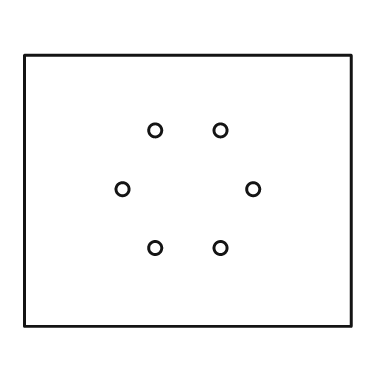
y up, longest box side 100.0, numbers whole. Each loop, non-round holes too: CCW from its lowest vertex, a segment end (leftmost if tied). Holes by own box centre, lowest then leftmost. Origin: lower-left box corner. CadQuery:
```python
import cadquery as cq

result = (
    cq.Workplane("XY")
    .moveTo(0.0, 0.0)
    .lineTo(100.0, 0.0)
    .lineTo(100.0, 83.0)
    .lineTo(0.0, 83.0)
    .close()
    .moveTo(40.0, 24.0)
    .circle(2.0)
    .moveTo(60.0, 24.0)
    .circle(2.0)
    .moveTo(30.0, 42.0)
    .circle(2.0)
    .moveTo(70.0, 42.0)
    .circle(2.0)
    .moveTo(40.0, 60.0)
    .circle(2.0)
    .moveTo(60.0, 60.0)
    .circle(2.0)
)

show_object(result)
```